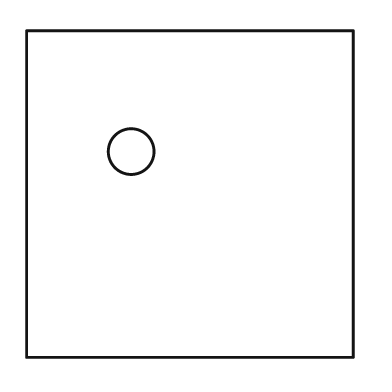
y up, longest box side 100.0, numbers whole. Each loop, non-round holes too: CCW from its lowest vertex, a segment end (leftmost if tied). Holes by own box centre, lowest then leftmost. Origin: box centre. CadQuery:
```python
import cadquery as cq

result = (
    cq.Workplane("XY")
    .moveTo(-50.0, -50.0)
    .lineTo(50.0, -50.0)
    .lineTo(50.0, 50.0)
    .lineTo(-50.0, 50.0)
    .close()
    .moveTo(-18.0, 13.0)
    .circle(7.0)
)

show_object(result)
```